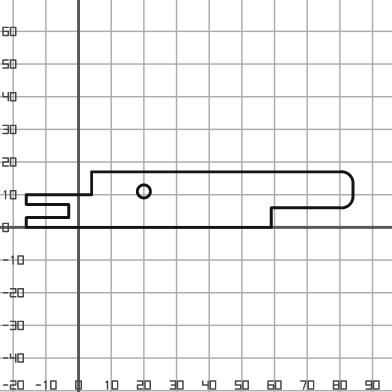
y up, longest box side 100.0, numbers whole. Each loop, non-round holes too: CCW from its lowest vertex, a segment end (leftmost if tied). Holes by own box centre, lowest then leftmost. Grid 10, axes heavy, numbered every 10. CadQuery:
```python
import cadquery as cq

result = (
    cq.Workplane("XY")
    .moveTo(-16.0, 0.0)
    .lineTo(59.0, 0.0)
    .lineTo(59.0, 6.0)
    .lineTo(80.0, 6.0)
    .threePointArc((83.0, 7.0), (84.0, 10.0))
    .lineTo(84.0, 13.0)
    .threePointArc((83.0, 16.0), (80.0, 17.0))
    .lineTo(4.0, 17.0)
    .lineTo(4.0, 10.0)
    .lineTo(-16.0, 10.0)
    .lineTo(-16.0, 7.0)
    .lineTo(-3.0, 7.0)
    .lineTo(-3.0, 3.0)
    .lineTo(-16.0, 3.0)
    .close()
    .moveTo(20.0, 11.0)
    .circle(2.0)
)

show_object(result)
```